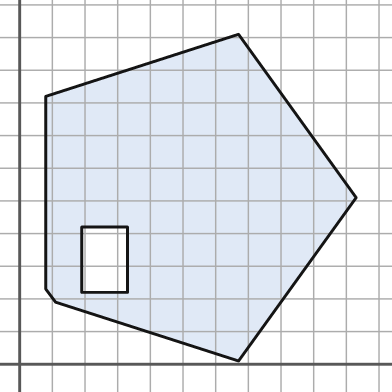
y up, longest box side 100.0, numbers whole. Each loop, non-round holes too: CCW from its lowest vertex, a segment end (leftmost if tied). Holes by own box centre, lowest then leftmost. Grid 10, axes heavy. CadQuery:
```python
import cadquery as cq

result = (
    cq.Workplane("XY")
    .moveTo(67.0, 1.0)
    .lineTo(103.0, 51.0)
    .lineTo(67.0, 101.0)
    .lineTo(8.0, 82.0)
    .lineTo(8.0, 23.0)
    .lineTo(11.0, 19.0)
    .close()
    .moveTo(19.0, 22.0)
    .lineTo(33.0, 22.0)
    .lineTo(33.0, 42.0)
    .lineTo(19.0, 42.0)
    .close()
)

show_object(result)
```